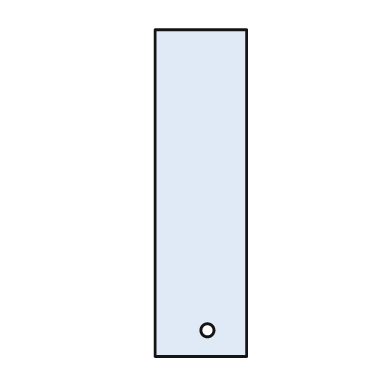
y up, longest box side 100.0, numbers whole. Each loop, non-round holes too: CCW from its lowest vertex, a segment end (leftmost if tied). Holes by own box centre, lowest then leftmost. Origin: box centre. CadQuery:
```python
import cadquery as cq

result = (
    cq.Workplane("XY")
    .moveTo(-14.0, -50.0)
    .lineTo(14.0, -50.0)
    .lineTo(14.0, 50.0)
    .lineTo(-14.0, 50.0)
    .close()
    .moveTo(2.0, -42.0)
    .circle(2.0)
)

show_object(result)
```